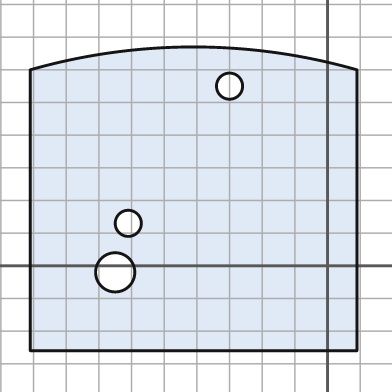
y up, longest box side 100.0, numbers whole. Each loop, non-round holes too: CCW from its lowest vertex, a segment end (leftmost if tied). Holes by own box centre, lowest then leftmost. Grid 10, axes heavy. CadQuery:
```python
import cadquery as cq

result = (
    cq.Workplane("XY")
    .moveTo(-91.0, -26.0)
    .lineTo(9.0, -26.0)
    .lineTo(9.0, 60.0)
    .threePointArc((-41.0, 67.0), (-91.0, 60.0))
    .close()
    .moveTo(-65.0, -2.0)
    .circle(6.0)
    .moveTo(-61.0, 13.0)
    .circle(4.0)
    .moveTo(-30.0, 55.0)
    .circle(4.0)
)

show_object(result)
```